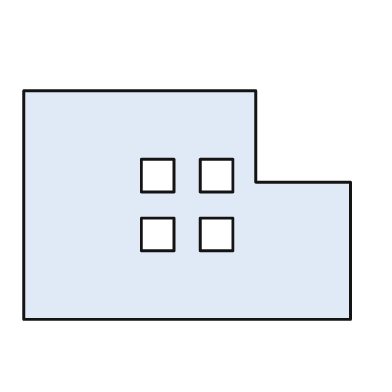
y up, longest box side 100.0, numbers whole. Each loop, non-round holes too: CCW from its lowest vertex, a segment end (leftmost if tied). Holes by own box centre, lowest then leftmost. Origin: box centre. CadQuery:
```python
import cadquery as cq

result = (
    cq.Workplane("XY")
    .moveTo(-50.0, -35.0)
    .lineTo(50.0, -35.0)
    .lineTo(50.0, 7.0)
    .lineTo(21.0, 7.0)
    .lineTo(21.0, 35.0)
    .lineTo(-50.0, 35.0)
    .close()
    .moveTo(-14.0, -14.0)
    .lineTo(-4.0, -14.0)
    .lineTo(-4.0, -4.0)
    .lineTo(-14.0, -4.0)
    .close()
    .moveTo(4.0, -14.0)
    .lineTo(14.0, -14.0)
    .lineTo(14.0, -4.0)
    .lineTo(4.0, -4.0)
    .close()
    .moveTo(-14.0, 4.0)
    .lineTo(-4.0, 4.0)
    .lineTo(-4.0, 14.0)
    .lineTo(-14.0, 14.0)
    .close()
    .moveTo(4.0, 4.0)
    .lineTo(14.0, 4.0)
    .lineTo(14.0, 14.0)
    .lineTo(4.0, 14.0)
    .close()
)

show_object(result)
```